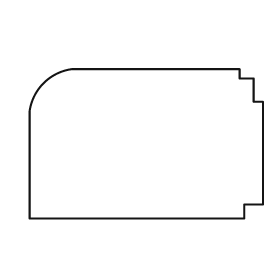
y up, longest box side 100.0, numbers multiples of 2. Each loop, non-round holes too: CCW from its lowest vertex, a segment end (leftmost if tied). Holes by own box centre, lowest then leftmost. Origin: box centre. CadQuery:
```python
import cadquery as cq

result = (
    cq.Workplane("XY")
    .moveTo(-50.0, -32.0)
    .lineTo(42.0, -32.0)
    .lineTo(42.0, -26.0)
    .lineTo(50.0, -26.0)
    .lineTo(50.0, 18.0)
    .lineTo(46.0, 18.0)
    .lineTo(46.0, 28.0)
    .lineTo(40.0, 28.0)
    .lineTo(40.0, 32.0)
    .lineTo(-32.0, 32.0)
    .threePointArc((-44.0, 26.0), (-50.0, 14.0))
    .close()
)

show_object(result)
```